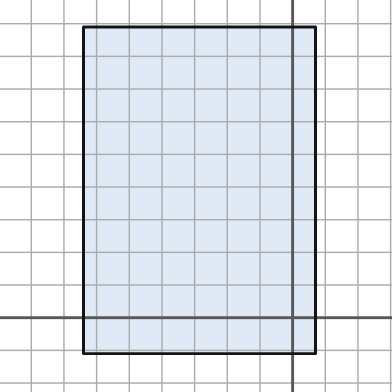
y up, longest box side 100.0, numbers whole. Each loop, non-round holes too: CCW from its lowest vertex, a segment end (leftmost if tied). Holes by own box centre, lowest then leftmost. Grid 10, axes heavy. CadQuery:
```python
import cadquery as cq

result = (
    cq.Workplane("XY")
    .moveTo(-64.0, -11.0)
    .lineTo(7.0, -11.0)
    .lineTo(7.0, 89.0)
    .lineTo(-64.0, 89.0)
    .close()
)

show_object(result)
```